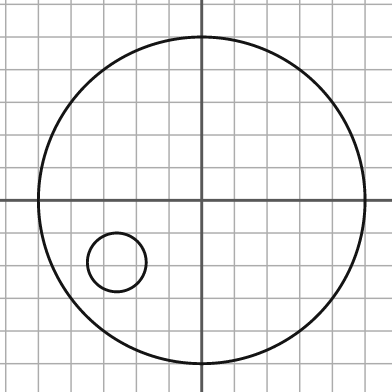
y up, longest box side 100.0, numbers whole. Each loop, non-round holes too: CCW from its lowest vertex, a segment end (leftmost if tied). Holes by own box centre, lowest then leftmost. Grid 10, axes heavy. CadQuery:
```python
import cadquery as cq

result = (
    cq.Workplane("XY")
    .moveTo(0.0, 0.0)
    .circle(50.0)
    .moveTo(-26.0, -19.0)
    .circle(9.0)
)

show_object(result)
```